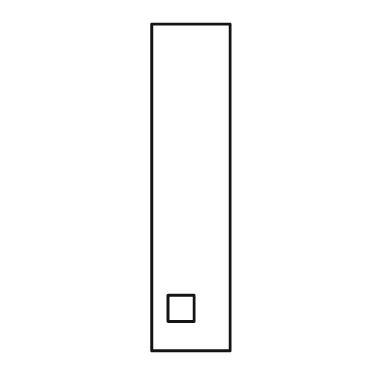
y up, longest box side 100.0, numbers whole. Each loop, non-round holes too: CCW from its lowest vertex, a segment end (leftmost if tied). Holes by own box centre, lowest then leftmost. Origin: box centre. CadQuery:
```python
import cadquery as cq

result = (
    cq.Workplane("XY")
    .moveTo(-12.0, -50.0)
    .lineTo(12.0, -50.0)
    .lineTo(12.0, 50.0)
    .lineTo(-12.0, 50.0)
    .close()
    .moveTo(-7.0, -41.0)
    .lineTo(1.0, -41.0)
    .lineTo(1.0, -33.0)
    .lineTo(-7.0, -33.0)
    .close()
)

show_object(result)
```